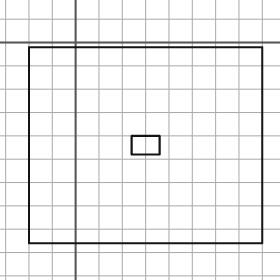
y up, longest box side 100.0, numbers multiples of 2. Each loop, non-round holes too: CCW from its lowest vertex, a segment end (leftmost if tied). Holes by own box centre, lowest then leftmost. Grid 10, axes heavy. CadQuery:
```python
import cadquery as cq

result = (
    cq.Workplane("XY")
    .moveTo(-20.0, -86.0)
    .lineTo(80.0, -86.0)
    .lineTo(80.0, -2.0)
    .lineTo(-20.0, -2.0)
    .close()
    .moveTo(24.0, -48.0)
    .lineTo(36.0, -48.0)
    .lineTo(36.0, -40.0)
    .lineTo(24.0, -40.0)
    .close()
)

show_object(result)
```